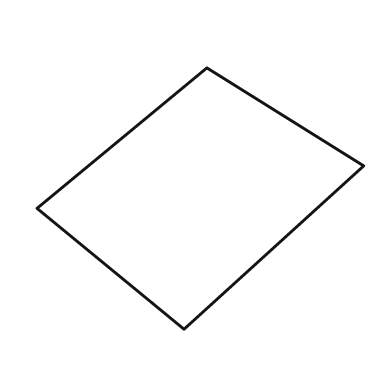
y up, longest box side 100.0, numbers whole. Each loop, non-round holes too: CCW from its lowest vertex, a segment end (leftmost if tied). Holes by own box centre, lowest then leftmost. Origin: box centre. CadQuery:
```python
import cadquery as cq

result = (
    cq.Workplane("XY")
    .moveTo(-5.0, -40.0)
    .lineTo(50.0, 10.0)
    .lineTo(2.0, 40.0)
    .lineTo(-50.0, -3.0)
    .close()
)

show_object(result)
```